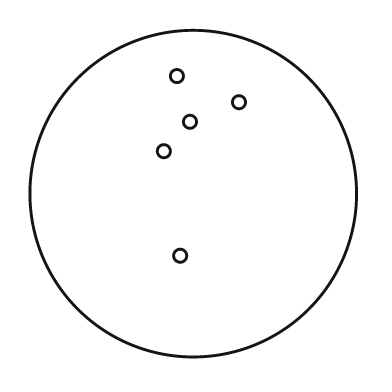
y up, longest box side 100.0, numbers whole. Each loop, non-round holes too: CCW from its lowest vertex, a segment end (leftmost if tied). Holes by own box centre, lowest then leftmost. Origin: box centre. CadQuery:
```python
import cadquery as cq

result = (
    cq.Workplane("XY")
    .moveTo(0.0, 0.0)
    .circle(50.0)
    .moveTo(-4.0, -19.0)
    .circle(2.0)
    .moveTo(-9.0, 13.0)
    .circle(2.0)
    .moveTo(-1.0, 22.0)
    .circle(2.0)
    .moveTo(14.0, 28.0)
    .circle(2.0)
    .moveTo(-5.0, 36.0)
    .circle(2.0)
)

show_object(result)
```